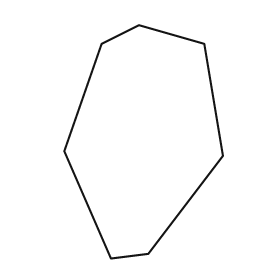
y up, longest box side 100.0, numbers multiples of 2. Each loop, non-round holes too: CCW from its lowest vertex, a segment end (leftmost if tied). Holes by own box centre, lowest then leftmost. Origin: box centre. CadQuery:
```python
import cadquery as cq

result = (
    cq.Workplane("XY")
    .moveTo(-14.0, -50.0)
    .lineTo(2.0, -48.0)
    .lineTo(34.0, -6.0)
    .lineTo(26.0, 42.0)
    .lineTo(-2.0, 50.0)
    .lineTo(-18.0, 42.0)
    .lineTo(-34.0, -4.0)
    .close()
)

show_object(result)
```